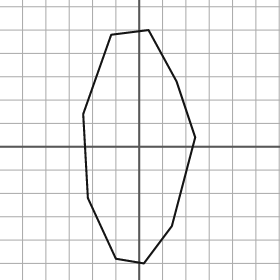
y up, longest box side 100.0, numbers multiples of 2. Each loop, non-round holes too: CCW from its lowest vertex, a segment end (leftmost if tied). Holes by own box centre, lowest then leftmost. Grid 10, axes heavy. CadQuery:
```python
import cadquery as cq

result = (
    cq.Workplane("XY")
    .moveTo(2.0, -50.0)
    .lineTo(14.0, -34.0)
    .lineTo(24.0, 4.0)
    .lineTo(16.0, 28.0)
    .lineTo(4.0, 50.0)
    .lineTo(-12.0, 48.0)
    .lineTo(-24.0, 14.0)
    .lineTo(-22.0, -22.0)
    .lineTo(-10.0, -48.0)
    .close()
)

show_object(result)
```